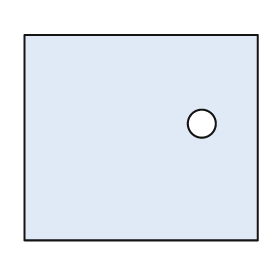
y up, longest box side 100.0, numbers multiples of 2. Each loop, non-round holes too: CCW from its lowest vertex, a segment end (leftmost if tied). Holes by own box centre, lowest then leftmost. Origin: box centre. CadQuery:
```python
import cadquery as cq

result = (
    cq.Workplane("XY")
    .moveTo(-50.0, -44.0)
    .lineTo(50.0, -44.0)
    .lineTo(50.0, 44.0)
    .lineTo(-50.0, 44.0)
    .close()
    .moveTo(26.0, 6.0)
    .circle(6.0)
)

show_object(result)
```